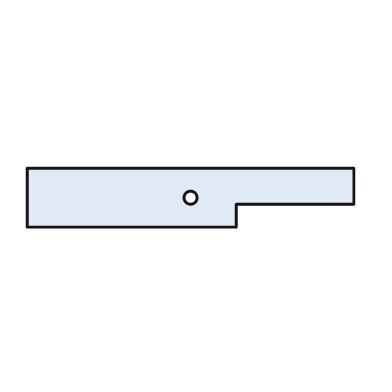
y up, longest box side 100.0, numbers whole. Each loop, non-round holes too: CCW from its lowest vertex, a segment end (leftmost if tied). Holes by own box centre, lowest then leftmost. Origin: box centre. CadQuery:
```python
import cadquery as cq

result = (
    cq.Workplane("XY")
    .moveTo(-50.0, -9.0)
    .lineTo(14.0, -9.0)
    .lineTo(14.0, -2.0)
    .lineTo(50.0, -2.0)
    .lineTo(50.0, 9.0)
    .lineTo(-50.0, 9.0)
    .close()
    .moveTo(0.0, 0.0)
    .circle(2.0)
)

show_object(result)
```